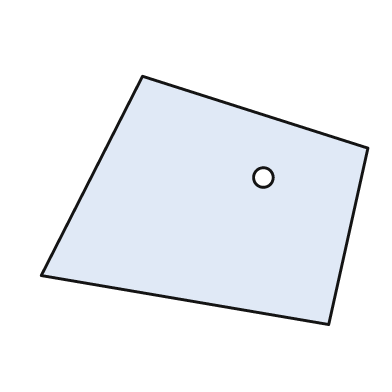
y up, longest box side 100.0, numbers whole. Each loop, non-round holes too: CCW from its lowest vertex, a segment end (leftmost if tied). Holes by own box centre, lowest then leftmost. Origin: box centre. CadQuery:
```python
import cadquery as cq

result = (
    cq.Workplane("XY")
    .moveTo(38.0, -38.0)
    .lineTo(50.0, 16.0)
    .lineTo(-19.0, 38.0)
    .lineTo(-50.0, -23.0)
    .close()
    .moveTo(18.0, 7.0)
    .circle(3.0)
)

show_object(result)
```